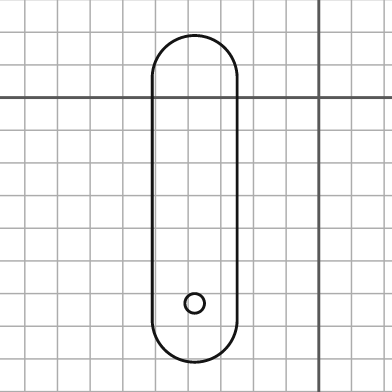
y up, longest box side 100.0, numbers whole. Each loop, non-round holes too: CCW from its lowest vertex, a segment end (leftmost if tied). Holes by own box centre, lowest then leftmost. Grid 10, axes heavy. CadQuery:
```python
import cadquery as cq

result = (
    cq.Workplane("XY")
    .moveTo(-51.0, -68.0)
    .threePointArc((-38.0, -81.0), (-25.0, -68.0))
    .lineTo(-25.0, 6.0)
    .threePointArc((-38.0, 19.0), (-51.0, 6.0))
    .close()
    .moveTo(-38.0, -63.0)
    .circle(3.0)
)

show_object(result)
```